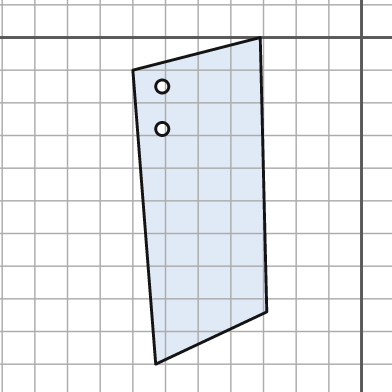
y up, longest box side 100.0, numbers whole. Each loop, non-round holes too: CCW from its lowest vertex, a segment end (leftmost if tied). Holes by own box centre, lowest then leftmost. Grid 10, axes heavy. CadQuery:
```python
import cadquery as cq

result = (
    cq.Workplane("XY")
    .moveTo(-63.0, -100.0)
    .lineTo(-29.0, -84.0)
    .lineTo(-31.0, 0.0)
    .lineTo(-70.0, -10.0)
    .close()
    .moveTo(-61.0, -28.0)
    .circle(2.0)
    .moveTo(-61.0, -15.0)
    .circle(2.0)
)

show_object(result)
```